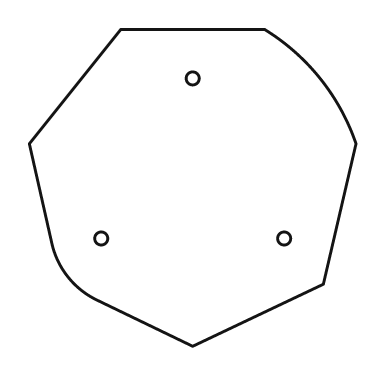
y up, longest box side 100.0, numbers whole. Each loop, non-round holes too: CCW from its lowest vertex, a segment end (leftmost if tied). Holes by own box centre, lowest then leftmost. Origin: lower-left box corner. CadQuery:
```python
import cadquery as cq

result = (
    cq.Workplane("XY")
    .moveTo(50.0, 0.0)
    .lineTo(90.0, 19.0)
    .lineTo(100.0, 62.0)
    .threePointArc((89.0, 82.0), (72.0, 97.0))
    .lineTo(28.0, 97.0)
    .lineTo(0.0, 62.0)
    .lineTo(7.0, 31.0)
    .threePointArc((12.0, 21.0), (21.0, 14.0))
    .close()
    .moveTo(22.0, 33.0)
    .circle(2.0)
    .moveTo(78.0, 33.0)
    .circle(2.0)
    .moveTo(50.0, 82.0)
    .circle(2.0)
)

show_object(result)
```